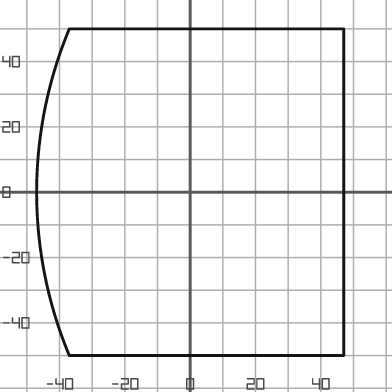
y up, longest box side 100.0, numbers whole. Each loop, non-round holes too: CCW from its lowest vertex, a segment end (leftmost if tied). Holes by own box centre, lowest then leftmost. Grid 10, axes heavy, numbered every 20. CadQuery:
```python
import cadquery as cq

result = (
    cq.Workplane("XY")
    .moveTo(-37.0, -50.0)
    .lineTo(47.0, -50.0)
    .lineTo(47.0, 50.0)
    .lineTo(-37.0, 50.0)
    .threePointArc((-47.0, 0.0), (-37.0, -50.0))
    .close()
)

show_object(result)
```